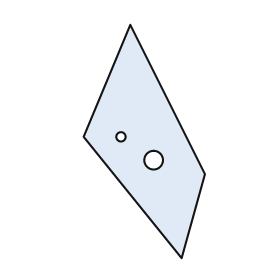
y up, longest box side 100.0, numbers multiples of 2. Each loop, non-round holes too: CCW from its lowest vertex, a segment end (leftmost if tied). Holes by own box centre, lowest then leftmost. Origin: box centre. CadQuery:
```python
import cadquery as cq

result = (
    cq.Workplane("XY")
    .moveTo(16.0, -50.0)
    .lineTo(26.0, -14.0)
    .lineTo(-6.0, 50.0)
    .lineTo(-26.0, 2.0)
    .close()
    .moveTo(4.0, -8.0)
    .circle(4.0)
    .moveTo(-10.0, 2.0)
    .circle(2.0)
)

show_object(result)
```